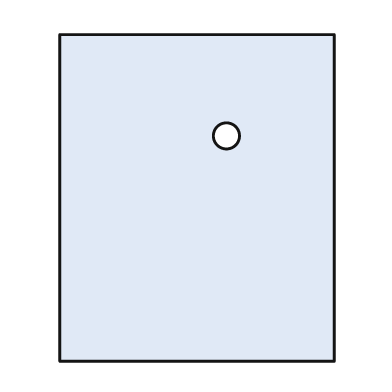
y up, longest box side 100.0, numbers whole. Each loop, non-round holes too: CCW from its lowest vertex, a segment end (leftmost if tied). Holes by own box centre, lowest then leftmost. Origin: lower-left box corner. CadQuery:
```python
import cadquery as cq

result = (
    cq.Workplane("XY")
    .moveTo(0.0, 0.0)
    .lineTo(84.0, 0.0)
    .lineTo(84.0, 100.0)
    .lineTo(0.0, 100.0)
    .close()
    .moveTo(51.0, 69.0)
    .circle(4.0)
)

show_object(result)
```